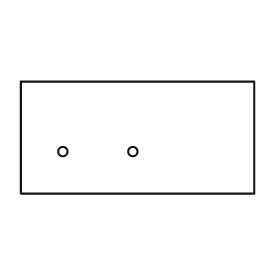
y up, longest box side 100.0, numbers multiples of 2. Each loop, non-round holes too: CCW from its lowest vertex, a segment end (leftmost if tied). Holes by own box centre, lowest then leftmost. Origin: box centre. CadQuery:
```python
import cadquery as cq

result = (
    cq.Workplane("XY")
    .moveTo(-50.0, -24.0)
    .lineTo(50.0, -24.0)
    .lineTo(50.0, 24.0)
    .lineTo(-50.0, 24.0)
    .close()
    .moveTo(-32.0, -6.0)
    .circle(2.0)
    .moveTo(-2.0, -6.0)
    .circle(2.0)
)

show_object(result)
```